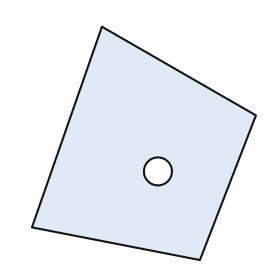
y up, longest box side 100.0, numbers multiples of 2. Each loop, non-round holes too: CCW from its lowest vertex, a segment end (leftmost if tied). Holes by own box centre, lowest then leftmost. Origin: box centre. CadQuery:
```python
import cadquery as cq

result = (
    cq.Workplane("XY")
    .moveTo(24.0, -50.0)
    .lineTo(48.0, 12.0)
    .lineTo(-18.0, 50.0)
    .lineTo(-48.0, -36.0)
    .close()
    .moveTo(6.0, -12.0)
    .circle(6.0)
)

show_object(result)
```